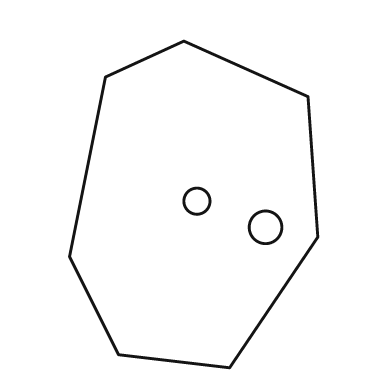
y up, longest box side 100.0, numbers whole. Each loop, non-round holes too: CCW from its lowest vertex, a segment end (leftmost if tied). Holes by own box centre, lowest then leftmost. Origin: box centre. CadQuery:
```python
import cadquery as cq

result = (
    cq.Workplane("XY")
    .moveTo(11.0, -50.0)
    .lineTo(38.0, -10.0)
    .lineTo(35.0, 33.0)
    .lineTo(-3.0, 50.0)
    .lineTo(-27.0, 39.0)
    .lineTo(-38.0, -16.0)
    .lineTo(-23.0, -46.0)
    .close()
    .moveTo(22.0, -7.0)
    .circle(5.0)
    .moveTo(1.0, 1.0)
    .circle(4.0)
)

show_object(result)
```